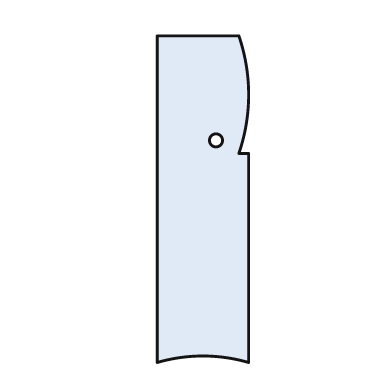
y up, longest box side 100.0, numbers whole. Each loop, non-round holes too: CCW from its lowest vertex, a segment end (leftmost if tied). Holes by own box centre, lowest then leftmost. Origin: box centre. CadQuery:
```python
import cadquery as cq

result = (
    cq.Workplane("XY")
    .moveTo(-14.0, -50.0)
    .threePointArc((0.0, -48.0), (14.0, -50.0))
    .lineTo(14.0, 14.0)
    .lineTo(11.0, 14.0)
    .threePointArc((14.0, 32.0), (11.0, 50.0))
    .lineTo(-14.0, 50.0)
    .close()
    .moveTo(4.0, 18.0)
    .circle(2.0)
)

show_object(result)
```